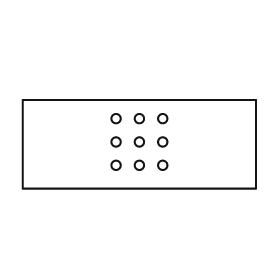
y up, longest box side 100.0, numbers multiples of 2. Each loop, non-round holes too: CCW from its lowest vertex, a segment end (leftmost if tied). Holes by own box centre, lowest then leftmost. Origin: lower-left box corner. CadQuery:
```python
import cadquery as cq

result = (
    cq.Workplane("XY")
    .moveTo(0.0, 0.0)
    .lineTo(100.0, 0.0)
    .lineTo(100.0, 38.0)
    .lineTo(0.0, 38.0)
    .close()
    .moveTo(40.0, 10.0)
    .circle(2.0)
    .moveTo(50.0, 10.0)
    .circle(2.0)
    .moveTo(60.0, 10.0)
    .circle(2.0)
    .moveTo(40.0, 20.0)
    .circle(2.0)
    .moveTo(50.0, 20.0)
    .circle(2.0)
    .moveTo(60.0, 20.0)
    .circle(2.0)
    .moveTo(40.0, 30.0)
    .circle(2.0)
    .moveTo(50.0, 30.0)
    .circle(2.0)
    .moveTo(60.0, 30.0)
    .circle(2.0)
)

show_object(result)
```